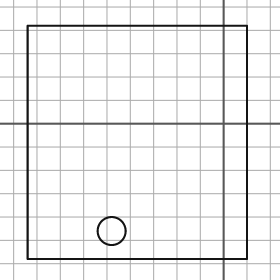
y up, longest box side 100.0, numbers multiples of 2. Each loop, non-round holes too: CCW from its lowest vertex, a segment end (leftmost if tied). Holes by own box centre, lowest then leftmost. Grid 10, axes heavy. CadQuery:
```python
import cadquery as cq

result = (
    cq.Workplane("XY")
    .moveTo(-84.0, -58.0)
    .lineTo(10.0, -58.0)
    .lineTo(10.0, 42.0)
    .lineTo(-84.0, 42.0)
    .close()
    .moveTo(-48.0, -46.0)
    .circle(6.0)
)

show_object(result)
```